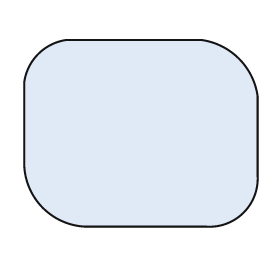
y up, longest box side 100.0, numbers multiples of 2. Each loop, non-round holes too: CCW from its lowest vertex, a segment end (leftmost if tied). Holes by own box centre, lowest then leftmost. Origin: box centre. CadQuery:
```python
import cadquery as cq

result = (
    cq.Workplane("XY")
    .moveTo(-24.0, -40.0)
    .lineTo(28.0, -40.0)
    .threePointArc((44.0, -34.0), (50.0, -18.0))
    .lineTo(50.0, 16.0)
    .threePointArc((42.0, 32.0), (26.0, 40.0))
    .lineTo(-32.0, 40.0)
    .threePointArc((-44.0, 34.0), (-50.0, 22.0))
    .lineTo(-50.0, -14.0)
    .threePointArc((-42.0, -32.0), (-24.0, -40.0))
    .close()
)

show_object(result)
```